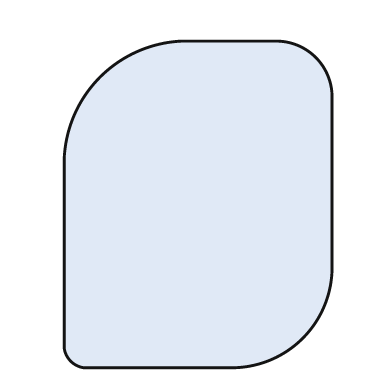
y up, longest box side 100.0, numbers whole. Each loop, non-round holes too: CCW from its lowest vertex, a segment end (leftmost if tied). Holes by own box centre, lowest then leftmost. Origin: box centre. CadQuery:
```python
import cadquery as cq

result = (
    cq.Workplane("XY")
    .moveTo(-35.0, -50.0)
    .lineTo(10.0, -50.0)
    .threePointArc((32.0, -41.0), (41.0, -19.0))
    .lineTo(41.0, 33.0)
    .threePointArc((36.0, 45.0), (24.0, 50.0))
    .lineTo(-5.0, 50.0)
    .threePointArc((-30.0, 39.0), (-41.0, 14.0))
    .lineTo(-41.0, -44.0)
    .threePointArc((-39.0, -48.0), (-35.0, -50.0))
    .close()
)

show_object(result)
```